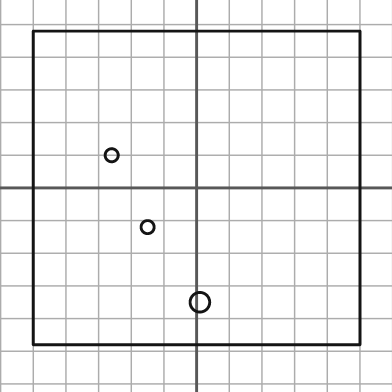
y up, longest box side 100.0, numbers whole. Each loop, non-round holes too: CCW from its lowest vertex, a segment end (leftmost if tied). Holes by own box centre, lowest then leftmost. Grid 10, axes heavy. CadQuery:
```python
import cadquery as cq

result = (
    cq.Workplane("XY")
    .moveTo(-50.0, -48.0)
    .lineTo(50.0, -48.0)
    .lineTo(50.0, 48.0)
    .lineTo(-50.0, 48.0)
    .close()
    .moveTo(1.0, -35.0)
    .circle(3.0)
    .moveTo(-15.0, -12.0)
    .circle(2.0)
    .moveTo(-26.0, 10.0)
    .circle(2.0)
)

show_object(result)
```